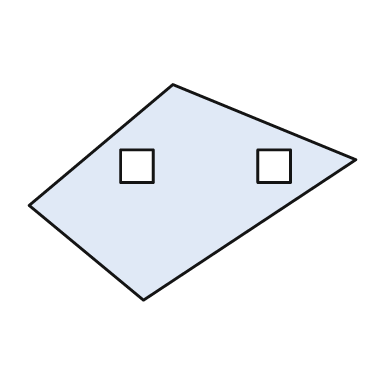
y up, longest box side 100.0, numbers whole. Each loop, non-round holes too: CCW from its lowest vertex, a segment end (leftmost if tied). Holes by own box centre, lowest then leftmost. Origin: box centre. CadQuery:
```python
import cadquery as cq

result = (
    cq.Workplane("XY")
    .moveTo(-15.0, -33.0)
    .lineTo(50.0, 10.0)
    .lineTo(-6.0, 33.0)
    .lineTo(-50.0, -4.0)
    .close()
    .moveTo(-22.0, 3.0)
    .lineTo(-12.0, 3.0)
    .lineTo(-12.0, 13.0)
    .lineTo(-22.0, 13.0)
    .close()
    .moveTo(20.0, 3.0)
    .lineTo(30.0, 3.0)
    .lineTo(30.0, 13.0)
    .lineTo(20.0, 13.0)
    .close()
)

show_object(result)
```